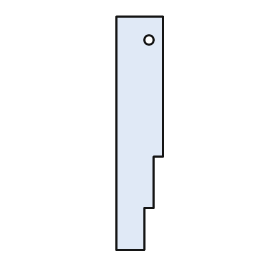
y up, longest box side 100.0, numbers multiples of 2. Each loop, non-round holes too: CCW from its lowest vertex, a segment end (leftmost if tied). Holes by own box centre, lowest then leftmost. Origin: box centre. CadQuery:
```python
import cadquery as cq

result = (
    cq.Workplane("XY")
    .moveTo(-10.0, -50.0)
    .lineTo(2.0, -50.0)
    .lineTo(2.0, -32.0)
    .lineTo(6.0, -32.0)
    .lineTo(6.0, -10.0)
    .lineTo(10.0, -10.0)
    .lineTo(10.0, 50.0)
    .lineTo(-10.0, 50.0)
    .close()
    .moveTo(4.0, 40.0)
    .circle(2.0)
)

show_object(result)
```